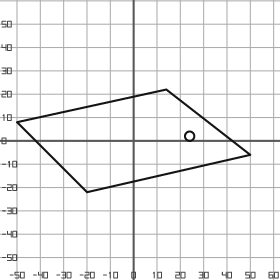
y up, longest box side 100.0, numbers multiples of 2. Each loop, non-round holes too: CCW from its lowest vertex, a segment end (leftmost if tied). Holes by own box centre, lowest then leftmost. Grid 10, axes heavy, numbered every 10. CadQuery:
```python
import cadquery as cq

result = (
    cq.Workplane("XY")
    .moveTo(-20.0, -22.0)
    .lineTo(50.0, -6.0)
    .lineTo(14.0, 22.0)
    .lineTo(-50.0, 8.0)
    .close()
    .moveTo(24.0, 2.0)
    .circle(2.0)
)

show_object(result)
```